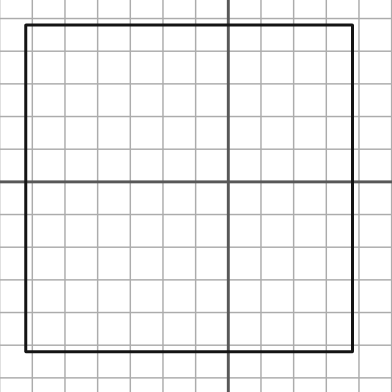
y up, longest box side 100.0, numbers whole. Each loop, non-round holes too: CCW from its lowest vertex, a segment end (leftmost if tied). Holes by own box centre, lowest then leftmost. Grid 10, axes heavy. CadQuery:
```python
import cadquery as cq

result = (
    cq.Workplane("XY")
    .moveTo(-62.0, -52.0)
    .lineTo(38.0, -52.0)
    .lineTo(38.0, 48.0)
    .lineTo(-62.0, 48.0)
    .close()
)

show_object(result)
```